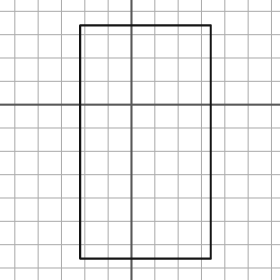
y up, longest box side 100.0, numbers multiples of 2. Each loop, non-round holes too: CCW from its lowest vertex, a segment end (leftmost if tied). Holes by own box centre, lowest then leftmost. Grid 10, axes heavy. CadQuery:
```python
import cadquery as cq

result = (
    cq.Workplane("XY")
    .moveTo(-22.0, -66.0)
    .lineTo(34.0, -66.0)
    .lineTo(34.0, 34.0)
    .lineTo(-22.0, 34.0)
    .close()
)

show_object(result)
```